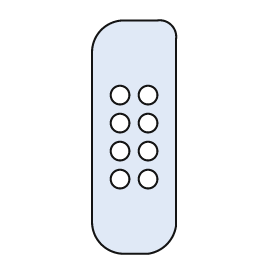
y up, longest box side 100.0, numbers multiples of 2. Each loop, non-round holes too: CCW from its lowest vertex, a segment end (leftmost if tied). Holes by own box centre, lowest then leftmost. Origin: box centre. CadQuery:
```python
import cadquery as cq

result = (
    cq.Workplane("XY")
    .moveTo(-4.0, -50.0)
    .lineTo(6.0, -50.0)
    .threePointArc((14.0, -46.0), (18.0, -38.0))
    .lineTo(18.0, 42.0)
    .threePointArc((16.0, 48.0), (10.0, 50.0))
    .lineTo(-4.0, 50.0)
    .threePointArc((-14.0, 46.0), (-18.0, 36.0))
    .lineTo(-18.0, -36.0)
    .threePointArc((-14.0, -46.0), (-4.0, -50.0))
    .close()
    .moveTo(-6.0, -18.0)
    .circle(4.0)
    .moveTo(6.0, -18.0)
    .circle(4.0)
    .moveTo(-6.0, -6.0)
    .circle(4.0)
    .moveTo(6.0, -6.0)
    .circle(4.0)
    .moveTo(-6.0, 6.0)
    .circle(4.0)
    .moveTo(6.0, 6.0)
    .circle(4.0)
    .moveTo(-6.0, 18.0)
    .circle(4.0)
    .moveTo(6.0, 18.0)
    .circle(4.0)
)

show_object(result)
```